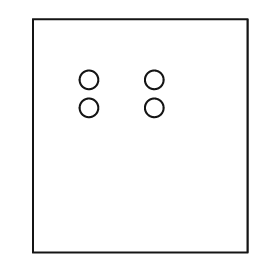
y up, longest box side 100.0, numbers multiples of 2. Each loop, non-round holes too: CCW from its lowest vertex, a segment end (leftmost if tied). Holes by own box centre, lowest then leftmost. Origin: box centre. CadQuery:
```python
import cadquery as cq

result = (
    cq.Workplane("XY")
    .moveTo(-46.0, -50.0)
    .lineTo(46.0, -50.0)
    .lineTo(46.0, 50.0)
    .lineTo(-46.0, 50.0)
    .close()
    .moveTo(-22.0, 12.0)
    .circle(4.0)
    .moveTo(6.0, 12.0)
    .circle(4.0)
    .moveTo(-22.0, 24.0)
    .circle(4.0)
    .moveTo(6.0, 24.0)
    .circle(4.0)
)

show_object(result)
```